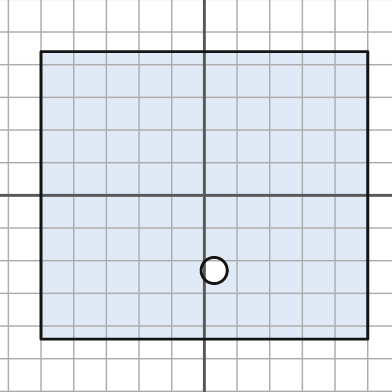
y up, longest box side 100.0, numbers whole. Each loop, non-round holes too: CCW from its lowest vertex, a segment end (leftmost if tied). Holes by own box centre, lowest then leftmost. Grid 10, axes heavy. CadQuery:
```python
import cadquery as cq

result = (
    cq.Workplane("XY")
    .moveTo(-50.0, -44.0)
    .lineTo(50.0, -44.0)
    .lineTo(50.0, 44.0)
    .lineTo(-50.0, 44.0)
    .close()
    .moveTo(3.0, -23.0)
    .circle(4.0)
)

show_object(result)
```